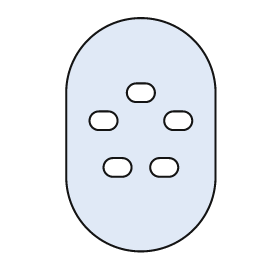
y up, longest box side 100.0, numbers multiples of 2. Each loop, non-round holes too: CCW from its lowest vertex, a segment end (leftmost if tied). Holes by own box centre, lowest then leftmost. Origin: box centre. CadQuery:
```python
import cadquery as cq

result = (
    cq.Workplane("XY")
    .moveTo(-32.0, -18.0)
    .threePointArc((0.0, -50.0), (32.0, -18.0))
    .lineTo(32.0, 18.0)
    .threePointArc((0.0, 50.0), (-32.0, 18.0))
    .close()
    .moveTo(-12.0, -18.0)
    .lineTo(-8.0, -18.0)
    .threePointArc((-4.0, -14.0), (-8.0, -10.0))
    .lineTo(-12.0, -10.0)
    .threePointArc((-16.0, -14.0), (-12.0, -18.0))
    .close()
    .moveTo(8.0, -18.0)
    .lineTo(12.0, -18.0)
    .threePointArc((16.0, -14.0), (12.0, -10.0))
    .lineTo(8.0, -10.0)
    .threePointArc((4.0, -14.0), (8.0, -18.0))
    .close()
    .moveTo(-18.0, 2.0)
    .lineTo(-14.0, 2.0)
    .threePointArc((-10.0, 6.0), (-14.0, 10.0))
    .lineTo(-18.0, 10.0)
    .threePointArc((-22.0, 6.0), (-18.0, 2.0))
    .close()
    .moveTo(14.0, 2.0)
    .lineTo(18.0, 2.0)
    .threePointArc((22.0, 6.0), (18.0, 10.0))
    .lineTo(14.0, 10.0)
    .threePointArc((10.0, 6.0), (14.0, 2.0))
    .close()
    .moveTo(-2.0, 14.0)
    .lineTo(2.0, 14.0)
    .threePointArc((6.0, 18.0), (2.0, 22.0))
    .lineTo(-2.0, 22.0)
    .threePointArc((-6.0, 18.0), (-2.0, 14.0))
    .close()
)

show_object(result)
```